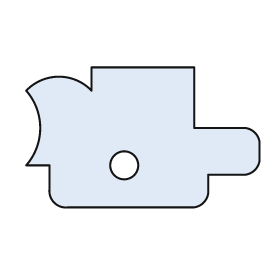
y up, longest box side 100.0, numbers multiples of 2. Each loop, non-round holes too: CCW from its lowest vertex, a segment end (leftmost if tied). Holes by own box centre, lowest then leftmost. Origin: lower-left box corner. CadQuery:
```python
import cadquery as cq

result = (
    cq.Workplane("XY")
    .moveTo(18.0, 0.0)
    .lineTo(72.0, 0.0)
    .threePointArc((76.0, 2.0), (78.0, 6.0))
    .lineTo(78.0, 14.0)
    .lineTo(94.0, 14.0)
    .threePointArc((98.0, 16.0), (100.0, 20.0))
    .lineTo(100.0, 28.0)
    .threePointArc((98.0, 32.0), (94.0, 34.0))
    .lineTo(72.0, 34.0)
    .lineTo(72.0, 60.0)
    .lineTo(28.0, 60.0)
    .lineTo(28.0, 50.0)
    .threePointArc((14.0, 56.0), (0.0, 50.0))
    .threePointArc((6.0, 34.0), (0.0, 18.0))
    .lineTo(10.0, 18.0)
    .lineTo(10.0, 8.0)
    .threePointArc((12.0, 2.0), (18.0, 0.0))
    .close()
    .moveTo(42.0, 18.0)
    .circle(6.0)
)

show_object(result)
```